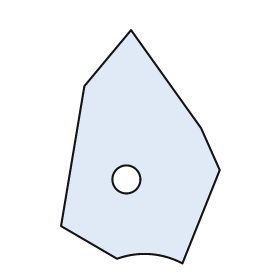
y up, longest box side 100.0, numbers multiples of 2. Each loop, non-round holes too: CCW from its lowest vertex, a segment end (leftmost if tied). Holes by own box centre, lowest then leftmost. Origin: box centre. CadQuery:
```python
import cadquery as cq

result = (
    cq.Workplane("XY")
    .moveTo(18.0, -50.0)
    .lineTo(34.0, -10.0)
    .lineTo(26.0, 8.0)
    .lineTo(-4.0, 50.0)
    .lineTo(-24.0, 26.0)
    .lineTo(-34.0, -34.0)
    .lineTo(-10.0, -48.0)
    .threePointArc((4.0, -46.0), (18.0, -50.0))
    .close()
    .moveTo(-6.0, -14.0)
    .circle(6.0)
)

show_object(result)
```